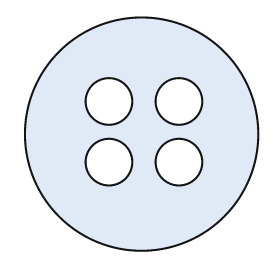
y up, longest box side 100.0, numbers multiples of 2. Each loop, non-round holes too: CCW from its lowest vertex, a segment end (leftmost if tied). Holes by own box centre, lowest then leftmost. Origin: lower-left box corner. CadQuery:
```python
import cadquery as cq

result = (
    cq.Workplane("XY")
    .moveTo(50.0, 50.0)
    .circle(50.0)
    .moveTo(36.0, 38.0)
    .circle(10.0)
    .moveTo(66.0, 38.0)
    .circle(10.0)
    .moveTo(36.0, 64.0)
    .circle(10.0)
    .moveTo(66.0, 64.0)
    .circle(10.0)
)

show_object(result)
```